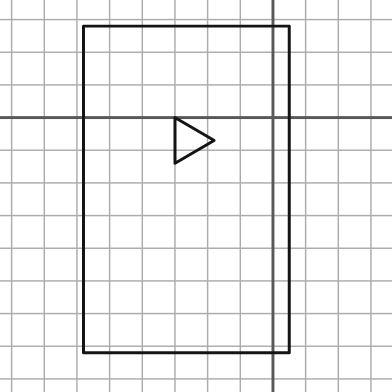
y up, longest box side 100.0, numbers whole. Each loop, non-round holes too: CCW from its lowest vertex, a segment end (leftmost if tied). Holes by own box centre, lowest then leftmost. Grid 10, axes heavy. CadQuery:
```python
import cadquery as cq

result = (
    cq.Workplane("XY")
    .moveTo(-58.0, -72.0)
    .lineTo(5.0, -72.0)
    .lineTo(5.0, 28.0)
    .lineTo(-58.0, 28.0)
    .close()
    .moveTo(-30.0, -14.0)
    .lineTo(-18.0, -7.0)
    .lineTo(-30.0, 0.0)
    .close()
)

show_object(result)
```